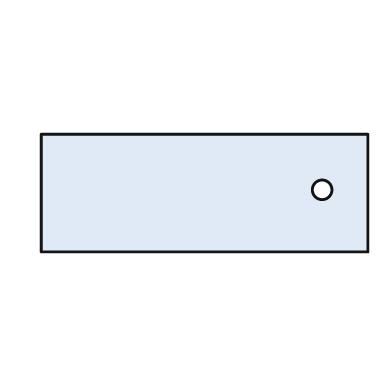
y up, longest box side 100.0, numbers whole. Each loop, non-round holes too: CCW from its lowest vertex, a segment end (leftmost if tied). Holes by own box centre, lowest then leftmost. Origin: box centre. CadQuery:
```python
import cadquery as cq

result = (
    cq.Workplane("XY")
    .moveTo(-50.0, -18.0)
    .lineTo(50.0, -18.0)
    .lineTo(50.0, 18.0)
    .lineTo(-50.0, 18.0)
    .close()
    .moveTo(36.0, 1.0)
    .circle(3.0)
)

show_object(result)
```